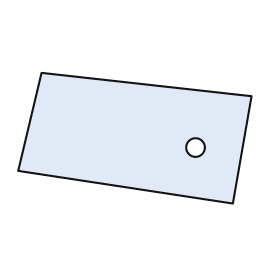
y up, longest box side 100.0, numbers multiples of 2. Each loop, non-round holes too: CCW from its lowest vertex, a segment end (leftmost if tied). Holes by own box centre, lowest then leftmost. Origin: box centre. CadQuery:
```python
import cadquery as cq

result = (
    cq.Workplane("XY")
    .moveTo(42.0, -28.0)
    .lineTo(50.0, 18.0)
    .lineTo(-40.0, 28.0)
    .lineTo(-50.0, -14.0)
    .close()
    .moveTo(26.0, -4.0)
    .circle(4.0)
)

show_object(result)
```